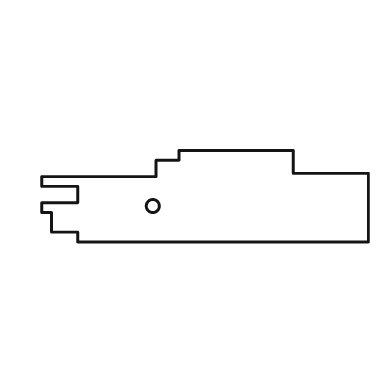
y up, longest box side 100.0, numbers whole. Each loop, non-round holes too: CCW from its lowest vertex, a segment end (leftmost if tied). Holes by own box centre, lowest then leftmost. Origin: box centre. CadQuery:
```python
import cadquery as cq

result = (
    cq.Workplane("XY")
    .moveTo(-39.0, -14.0)
    .lineTo(50.0, -14.0)
    .lineTo(50.0, 7.0)
    .lineTo(27.0, 7.0)
    .lineTo(27.0, 14.0)
    .lineTo(-8.0, 14.0)
    .lineTo(-8.0, 11.0)
    .lineTo(-15.0, 11.0)
    .lineTo(-15.0, 6.0)
    .lineTo(-50.0, 6.0)
    .lineTo(-50.0, 3.0)
    .lineTo(-39.0, 3.0)
    .lineTo(-39.0, -2.0)
    .lineTo(-50.0, -2.0)
    .lineTo(-50.0, -5.0)
    .lineTo(-47.0, -5.0)
    .lineTo(-47.0, -11.0)
    .lineTo(-39.0, -11.0)
    .close()
    .moveTo(-16.0, -3.0)
    .circle(2.0)
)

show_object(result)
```